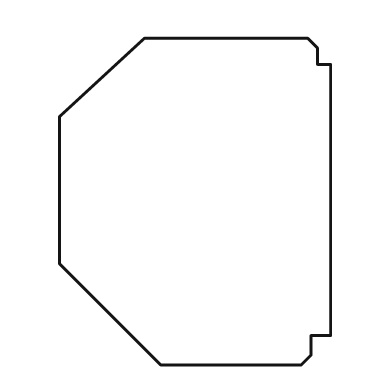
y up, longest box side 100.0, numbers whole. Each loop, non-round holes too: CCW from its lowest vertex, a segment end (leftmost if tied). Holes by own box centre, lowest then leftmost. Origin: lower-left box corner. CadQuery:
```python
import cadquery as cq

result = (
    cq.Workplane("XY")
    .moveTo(31.0, 0.0)
    .lineTo(74.0, 0.0)
    .lineTo(77.0, 3.0)
    .lineTo(77.0, 9.0)
    .lineTo(83.0, 9.0)
    .lineTo(83.0, 92.0)
    .lineTo(79.0, 92.0)
    .lineTo(79.0, 97.0)
    .lineTo(76.0, 100.0)
    .lineTo(26.0, 100.0)
    .lineTo(0.0, 76.0)
    .lineTo(0.0, 31.0)
    .close()
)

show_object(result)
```